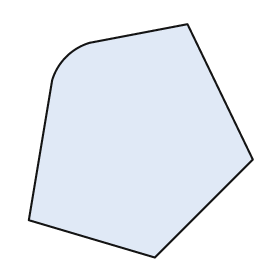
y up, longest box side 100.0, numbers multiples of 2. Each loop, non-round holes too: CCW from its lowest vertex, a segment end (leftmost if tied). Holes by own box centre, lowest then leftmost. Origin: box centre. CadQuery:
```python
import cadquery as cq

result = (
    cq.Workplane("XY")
    .moveTo(6.0, -50.0)
    .lineTo(48.0, -8.0)
    .lineTo(20.0, 50.0)
    .lineTo(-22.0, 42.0)
    .threePointArc((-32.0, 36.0), (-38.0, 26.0))
    .lineTo(-48.0, -34.0)
    .close()
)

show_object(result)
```